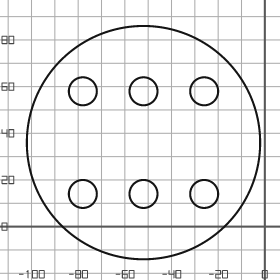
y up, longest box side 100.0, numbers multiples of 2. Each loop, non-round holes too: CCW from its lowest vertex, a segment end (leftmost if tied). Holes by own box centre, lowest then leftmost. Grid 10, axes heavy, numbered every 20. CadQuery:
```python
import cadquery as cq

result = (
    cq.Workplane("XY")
    .moveTo(-52.0, 36.0)
    .circle(50.0)
    .moveTo(-78.0, 14.0)
    .circle(6.0)
    .moveTo(-52.0, 14.0)
    .circle(6.0)
    .moveTo(-26.0, 14.0)
    .circle(6.0)
    .moveTo(-78.0, 58.0)
    .circle(6.0)
    .moveTo(-52.0, 58.0)
    .circle(6.0)
    .moveTo(-26.0, 58.0)
    .circle(6.0)
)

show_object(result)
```